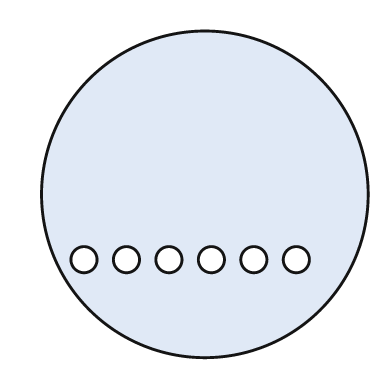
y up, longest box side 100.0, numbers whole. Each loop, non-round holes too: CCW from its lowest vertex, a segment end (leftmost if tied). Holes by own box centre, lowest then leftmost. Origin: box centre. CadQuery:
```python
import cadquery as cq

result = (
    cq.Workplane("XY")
    .moveTo(0.0, 0.0)
    .circle(50.0)
    .moveTo(-37.0, -20.0)
    .circle(4.0)
    .moveTo(-24.0, -20.0)
    .circle(4.0)
    .moveTo(-11.0, -20.0)
    .circle(4.0)
    .moveTo(2.0, -20.0)
    .circle(4.0)
    .moveTo(15.0, -20.0)
    .circle(4.0)
    .moveTo(28.0, -20.0)
    .circle(4.0)
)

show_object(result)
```